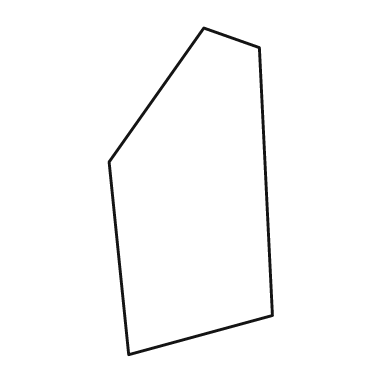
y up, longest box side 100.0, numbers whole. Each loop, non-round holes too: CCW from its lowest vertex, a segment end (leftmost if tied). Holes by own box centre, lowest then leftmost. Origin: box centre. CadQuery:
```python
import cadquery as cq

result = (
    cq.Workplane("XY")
    .moveTo(-19.0, -50.0)
    .lineTo(25.0, -38.0)
    .lineTo(21.0, 44.0)
    .lineTo(4.0, 50.0)
    .lineTo(-25.0, 9.0)
    .close()
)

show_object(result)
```